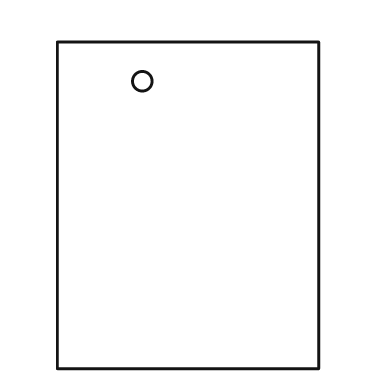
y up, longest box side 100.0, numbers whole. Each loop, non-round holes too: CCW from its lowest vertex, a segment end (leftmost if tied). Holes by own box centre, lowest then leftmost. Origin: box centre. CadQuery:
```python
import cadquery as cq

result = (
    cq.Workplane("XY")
    .moveTo(-40.0, -50.0)
    .lineTo(40.0, -50.0)
    .lineTo(40.0, 50.0)
    .lineTo(-40.0, 50.0)
    .close()
    .moveTo(-14.0, 38.0)
    .circle(3.0)
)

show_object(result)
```